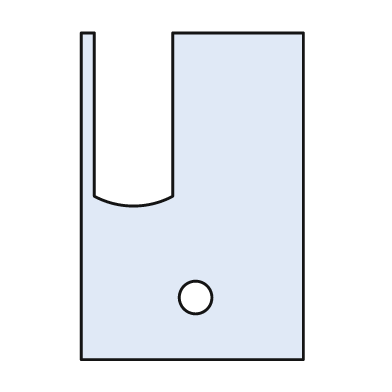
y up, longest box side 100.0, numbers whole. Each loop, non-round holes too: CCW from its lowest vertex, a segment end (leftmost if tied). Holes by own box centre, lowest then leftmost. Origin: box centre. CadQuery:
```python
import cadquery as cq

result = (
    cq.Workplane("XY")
    .moveTo(-34.0, -50.0)
    .lineTo(34.0, -50.0)
    .lineTo(34.0, 50.0)
    .lineTo(-6.0, 50.0)
    .lineTo(-6.0, 0.0)
    .threePointArc((-18.0, -3.0), (-30.0, 0.0))
    .lineTo(-30.0, 50.0)
    .lineTo(-34.0, 50.0)
    .close()
    .moveTo(1.0, -31.0)
    .circle(5.0)
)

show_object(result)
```